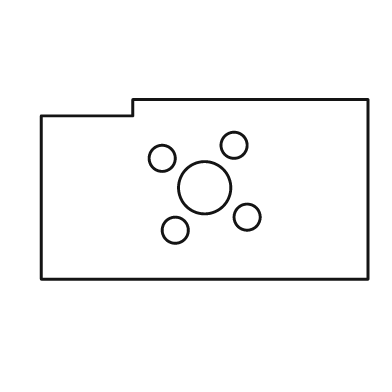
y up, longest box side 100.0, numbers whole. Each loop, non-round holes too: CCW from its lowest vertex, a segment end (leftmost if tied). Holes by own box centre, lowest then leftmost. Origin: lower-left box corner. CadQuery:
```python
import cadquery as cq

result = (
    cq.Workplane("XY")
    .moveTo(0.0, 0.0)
    .lineTo(100.0, 0.0)
    .lineTo(100.0, 55.0)
    .lineTo(28.0, 55.0)
    .lineTo(28.0, 50.0)
    .lineTo(0.0, 50.0)
    .close()
    .moveTo(41.0, 15.0)
    .circle(4.0)
    .moveTo(63.0, 19.0)
    .circle(4.0)
    .moveTo(50.0, 28.0)
    .circle(8.0)
    .moveTo(37.0, 37.0)
    .circle(4.0)
    .moveTo(59.0, 41.0)
    .circle(4.0)
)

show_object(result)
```